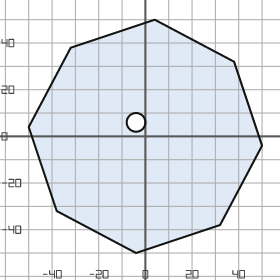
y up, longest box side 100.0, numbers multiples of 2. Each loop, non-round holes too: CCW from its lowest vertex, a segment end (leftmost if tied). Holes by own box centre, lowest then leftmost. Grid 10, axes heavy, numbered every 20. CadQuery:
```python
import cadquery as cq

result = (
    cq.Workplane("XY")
    .moveTo(-4.0, -50.0)
    .lineTo(32.0, -38.0)
    .lineTo(50.0, -4.0)
    .lineTo(38.0, 32.0)
    .lineTo(4.0, 50.0)
    .lineTo(-32.0, 38.0)
    .lineTo(-50.0, 4.0)
    .lineTo(-38.0, -32.0)
    .close()
    .moveTo(-4.0, 6.0)
    .circle(4.0)
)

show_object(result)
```